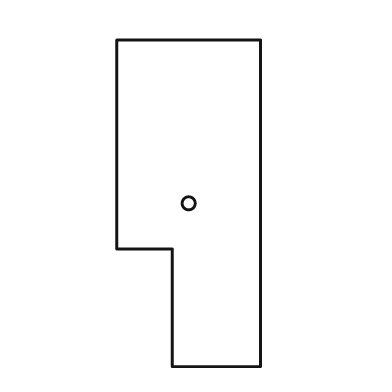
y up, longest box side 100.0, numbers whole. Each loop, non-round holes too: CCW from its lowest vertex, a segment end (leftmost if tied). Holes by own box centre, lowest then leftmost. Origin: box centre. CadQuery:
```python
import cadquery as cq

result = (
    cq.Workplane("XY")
    .moveTo(-5.0, -50.0)
    .lineTo(22.0, -50.0)
    .lineTo(22.0, 50.0)
    .lineTo(-22.0, 50.0)
    .lineTo(-22.0, -14.0)
    .lineTo(-5.0, -14.0)
    .close()
    .moveTo(0.0, 0.0)
    .circle(2.0)
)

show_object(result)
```